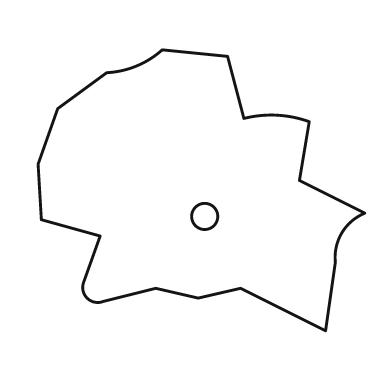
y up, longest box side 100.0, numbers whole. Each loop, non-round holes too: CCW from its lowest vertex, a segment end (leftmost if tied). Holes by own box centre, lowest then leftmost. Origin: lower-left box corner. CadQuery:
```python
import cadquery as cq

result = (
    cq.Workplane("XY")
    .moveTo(88.0, 0.0)
    .lineTo(91.0, 21.0)
    .threePointArc((93.0, 30.0), (100.0, 36.0))
    .lineTo(80.0, 46.0)
    .lineTo(83.0, 64.0)
    .threePointArc((73.0, 66.0), (63.0, 65.0))
    .lineTo(58.0, 84.0)
    .lineTo(38.0, 86.0)
    .threePointArc((30.0, 81.0), (21.0, 79.0))
    .lineTo(6.0, 68.0)
    .lineTo(0.0, 51.0)
    .lineTo(1.0, 34.0)
    .lineTo(19.0, 29.0)
    .lineTo(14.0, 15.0)
    .threePointArc((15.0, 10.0), (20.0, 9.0))
    .lineTo(36.0, 13.0)
    .lineTo(49.0, 10.0)
    .lineTo(62.0, 13.0)
    .close()
    .moveTo(51.0, 35.0)
    .circle(4.0)
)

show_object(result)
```